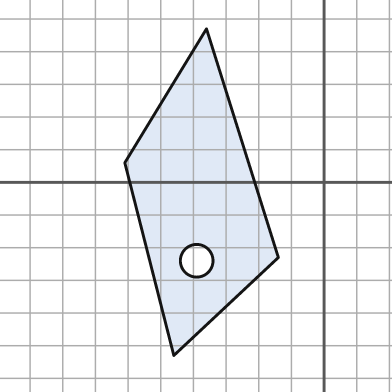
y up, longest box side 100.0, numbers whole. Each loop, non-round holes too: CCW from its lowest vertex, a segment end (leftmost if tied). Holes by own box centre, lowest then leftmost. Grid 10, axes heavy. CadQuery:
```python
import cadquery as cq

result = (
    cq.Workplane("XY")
    .moveTo(-46.0, -53.0)
    .lineTo(-14.0, -23.0)
    .lineTo(-36.0, 47.0)
    .lineTo(-61.0, 6.0)
    .close()
    .moveTo(-39.0, -24.0)
    .circle(5.0)
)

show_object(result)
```